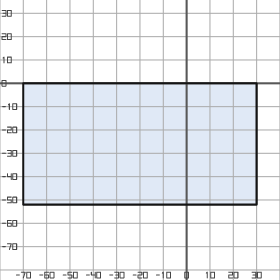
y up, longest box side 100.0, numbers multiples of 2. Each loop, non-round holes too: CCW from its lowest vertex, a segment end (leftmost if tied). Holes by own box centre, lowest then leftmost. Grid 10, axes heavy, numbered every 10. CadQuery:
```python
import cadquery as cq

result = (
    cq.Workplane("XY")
    .moveTo(-70.0, -52.0)
    .lineTo(30.0, -52.0)
    .lineTo(30.0, 0.0)
    .lineTo(-70.0, 0.0)
    .close()
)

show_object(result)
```